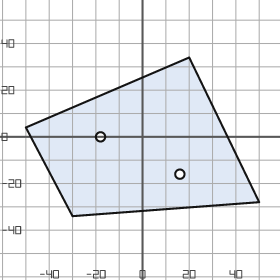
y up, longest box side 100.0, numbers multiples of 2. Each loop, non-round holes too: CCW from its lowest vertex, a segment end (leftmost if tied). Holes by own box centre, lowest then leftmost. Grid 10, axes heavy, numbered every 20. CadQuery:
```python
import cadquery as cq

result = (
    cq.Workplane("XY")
    .moveTo(-30.0, -34.0)
    .lineTo(50.0, -28.0)
    .lineTo(20.0, 34.0)
    .lineTo(-50.0, 4.0)
    .close()
    .moveTo(16.0, -16.0)
    .circle(2.0)
    .moveTo(-18.0, 0.0)
    .circle(2.0)
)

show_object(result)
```